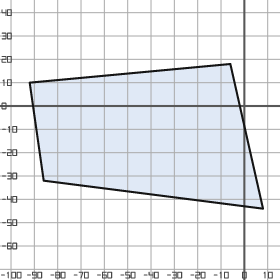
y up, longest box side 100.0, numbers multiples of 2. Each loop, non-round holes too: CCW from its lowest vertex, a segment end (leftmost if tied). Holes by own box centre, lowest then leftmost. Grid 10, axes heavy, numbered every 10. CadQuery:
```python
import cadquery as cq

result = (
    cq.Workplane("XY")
    .moveTo(8.0, -44.0)
    .lineTo(-6.0, 18.0)
    .lineTo(-92.0, 10.0)
    .lineTo(-86.0, -32.0)
    .close()
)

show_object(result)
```